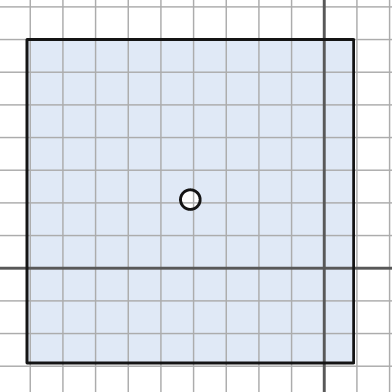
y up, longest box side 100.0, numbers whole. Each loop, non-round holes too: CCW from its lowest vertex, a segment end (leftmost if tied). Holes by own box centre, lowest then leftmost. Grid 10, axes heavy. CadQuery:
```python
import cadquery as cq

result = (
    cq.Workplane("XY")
    .moveTo(-91.0, -29.0)
    .lineTo(9.0, -29.0)
    .lineTo(9.0, 70.0)
    .lineTo(-91.0, 70.0)
    .close()
    .moveTo(-41.0, 21.0)
    .circle(3.0)
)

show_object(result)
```